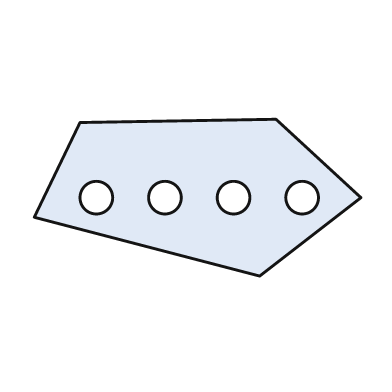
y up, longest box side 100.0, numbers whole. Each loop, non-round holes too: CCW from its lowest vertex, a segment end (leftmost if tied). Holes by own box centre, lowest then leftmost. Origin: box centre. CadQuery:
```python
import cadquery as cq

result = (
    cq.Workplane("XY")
    .moveTo(19.0, -24.0)
    .lineTo(50.0, 0.0)
    .lineTo(24.0, 24.0)
    .lineTo(-36.0, 23.0)
    .lineTo(-50.0, -6.0)
    .close()
    .moveTo(-31.0, 0.0)
    .circle(5.0)
    .moveTo(-10.0, 0.0)
    .circle(5.0)
    .moveTo(11.0, 0.0)
    .circle(5.0)
    .moveTo(32.0, 0.0)
    .circle(5.0)
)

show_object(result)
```